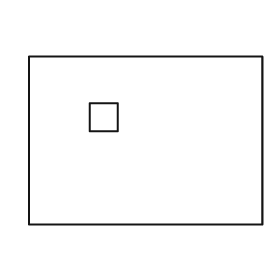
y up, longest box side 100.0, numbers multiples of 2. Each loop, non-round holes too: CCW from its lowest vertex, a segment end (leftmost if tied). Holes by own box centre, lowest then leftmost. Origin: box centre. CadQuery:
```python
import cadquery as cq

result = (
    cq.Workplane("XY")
    .moveTo(-50.0, -36.0)
    .lineTo(50.0, -36.0)
    .lineTo(50.0, 36.0)
    .lineTo(-50.0, 36.0)
    .close()
    .moveTo(-24.0, 4.0)
    .lineTo(-12.0, 4.0)
    .lineTo(-12.0, 16.0)
    .lineTo(-24.0, 16.0)
    .close()
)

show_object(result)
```